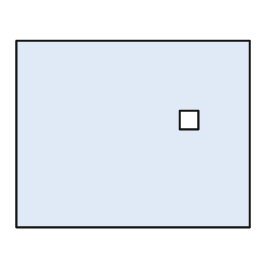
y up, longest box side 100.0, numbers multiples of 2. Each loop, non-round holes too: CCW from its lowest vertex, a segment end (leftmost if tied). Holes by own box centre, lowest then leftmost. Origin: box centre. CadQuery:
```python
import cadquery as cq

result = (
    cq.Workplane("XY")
    .moveTo(-50.0, -40.0)
    .lineTo(50.0, -40.0)
    .lineTo(50.0, 40.0)
    .lineTo(-50.0, 40.0)
    .close()
    .moveTo(20.0, 2.0)
    .lineTo(28.0, 2.0)
    .lineTo(28.0, 10.0)
    .lineTo(20.0, 10.0)
    .close()
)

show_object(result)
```